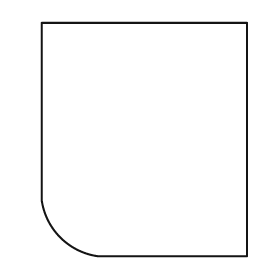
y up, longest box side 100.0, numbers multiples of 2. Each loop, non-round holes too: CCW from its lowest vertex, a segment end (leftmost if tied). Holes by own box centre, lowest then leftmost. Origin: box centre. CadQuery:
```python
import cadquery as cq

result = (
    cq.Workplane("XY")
    .moveTo(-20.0, -50.0)
    .lineTo(44.0, -50.0)
    .lineTo(44.0, 50.0)
    .lineTo(-44.0, 50.0)
    .lineTo(-44.0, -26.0)
    .threePointArc((-36.0, -42.0), (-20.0, -50.0))
    .close()
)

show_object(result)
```